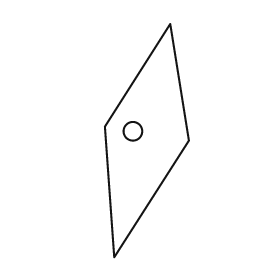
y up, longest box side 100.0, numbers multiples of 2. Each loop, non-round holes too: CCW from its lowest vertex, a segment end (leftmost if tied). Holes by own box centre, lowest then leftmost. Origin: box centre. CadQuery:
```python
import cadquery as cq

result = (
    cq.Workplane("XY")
    .moveTo(-14.0, -50.0)
    .lineTo(18.0, 0.0)
    .lineTo(10.0, 50.0)
    .lineTo(-18.0, 6.0)
    .close()
    .moveTo(-6.0, 4.0)
    .circle(4.0)
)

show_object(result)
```